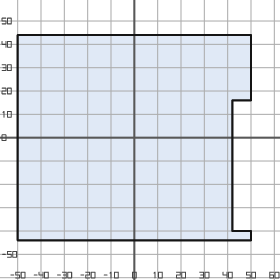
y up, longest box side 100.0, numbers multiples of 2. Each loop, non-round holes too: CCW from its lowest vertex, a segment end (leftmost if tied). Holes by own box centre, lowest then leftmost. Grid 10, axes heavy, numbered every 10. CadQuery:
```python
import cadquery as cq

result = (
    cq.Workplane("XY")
    .moveTo(-50.0, -44.0)
    .lineTo(50.0, -44.0)
    .lineTo(50.0, -40.0)
    .lineTo(42.0, -40.0)
    .lineTo(42.0, 16.0)
    .lineTo(50.0, 16.0)
    .lineTo(50.0, 44.0)
    .lineTo(-50.0, 44.0)
    .close()
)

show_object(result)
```